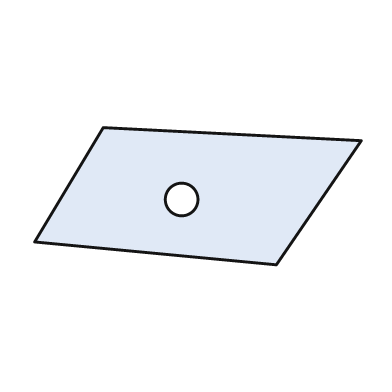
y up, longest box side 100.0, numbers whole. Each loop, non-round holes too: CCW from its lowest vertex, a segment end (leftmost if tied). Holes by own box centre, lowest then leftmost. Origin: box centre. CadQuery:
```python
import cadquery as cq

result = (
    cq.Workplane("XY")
    .moveTo(24.0, -21.0)
    .lineTo(50.0, 17.0)
    .lineTo(-29.0, 21.0)
    .lineTo(-50.0, -14.0)
    .close()
    .moveTo(-5.0, -1.0)
    .circle(5.0)
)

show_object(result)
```